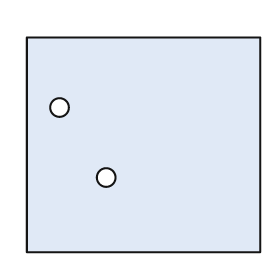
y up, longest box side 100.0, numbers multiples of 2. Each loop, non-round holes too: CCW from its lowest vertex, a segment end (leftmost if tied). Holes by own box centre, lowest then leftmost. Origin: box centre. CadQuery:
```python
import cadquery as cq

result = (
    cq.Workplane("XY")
    .moveTo(-50.0, -46.0)
    .lineTo(50.0, -46.0)
    .lineTo(50.0, 46.0)
    .lineTo(-50.0, 46.0)
    .close()
    .moveTo(-16.0, -14.0)
    .circle(4.0)
    .moveTo(-36.0, 16.0)
    .circle(4.0)
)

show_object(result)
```